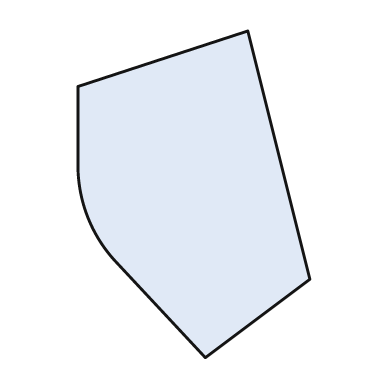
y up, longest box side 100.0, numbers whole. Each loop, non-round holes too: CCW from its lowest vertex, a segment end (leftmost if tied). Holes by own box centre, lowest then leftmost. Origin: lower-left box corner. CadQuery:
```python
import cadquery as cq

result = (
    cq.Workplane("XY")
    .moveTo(39.0, 0.0)
    .lineTo(71.0, 24.0)
    .lineTo(52.0, 100.0)
    .lineTo(0.0, 83.0)
    .lineTo(0.0, 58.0)
    .threePointArc((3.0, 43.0), (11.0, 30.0))
    .close()
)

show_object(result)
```